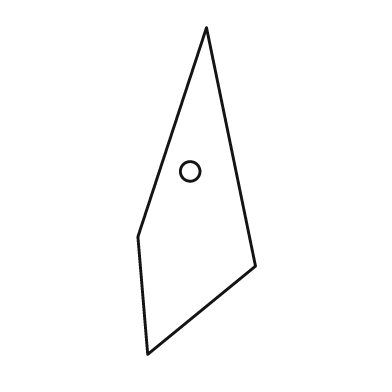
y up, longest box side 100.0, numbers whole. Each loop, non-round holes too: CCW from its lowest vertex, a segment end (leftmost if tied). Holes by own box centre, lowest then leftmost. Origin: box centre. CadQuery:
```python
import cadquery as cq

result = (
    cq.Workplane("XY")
    .moveTo(-15.0, -50.0)
    .lineTo(18.0, -23.0)
    .lineTo(3.0, 50.0)
    .lineTo(-18.0, -14.0)
    .close()
    .moveTo(-2.0, 6.0)
    .circle(3.0)
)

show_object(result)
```